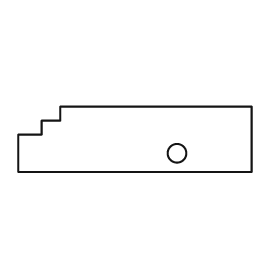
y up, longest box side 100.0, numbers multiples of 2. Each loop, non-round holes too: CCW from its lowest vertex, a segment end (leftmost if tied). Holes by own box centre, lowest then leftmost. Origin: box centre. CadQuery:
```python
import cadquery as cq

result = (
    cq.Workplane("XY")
    .moveTo(-50.0, -14.0)
    .lineTo(50.0, -14.0)
    .lineTo(50.0, 14.0)
    .lineTo(-32.0, 14.0)
    .lineTo(-32.0, 8.0)
    .lineTo(-40.0, 8.0)
    .lineTo(-40.0, 2.0)
    .lineTo(-50.0, 2.0)
    .close()
    .moveTo(18.0, -6.0)
    .circle(4.0)
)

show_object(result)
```